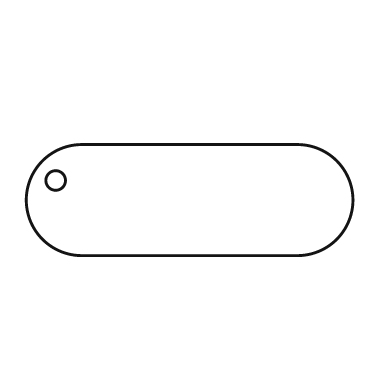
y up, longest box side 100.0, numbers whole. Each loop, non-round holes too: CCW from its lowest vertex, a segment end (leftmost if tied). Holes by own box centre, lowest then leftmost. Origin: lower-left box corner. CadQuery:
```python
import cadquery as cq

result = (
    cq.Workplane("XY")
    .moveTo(17.0, 0.0)
    .lineTo(83.0, 0.0)
    .threePointArc((100.0, 17.0), (83.0, 34.0))
    .lineTo(17.0, 34.0)
    .threePointArc((0.0, 17.0), (17.0, 0.0))
    .close()
    .moveTo(9.0, 23.0)
    .circle(3.0)
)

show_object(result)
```